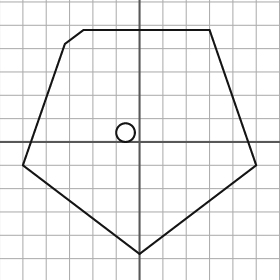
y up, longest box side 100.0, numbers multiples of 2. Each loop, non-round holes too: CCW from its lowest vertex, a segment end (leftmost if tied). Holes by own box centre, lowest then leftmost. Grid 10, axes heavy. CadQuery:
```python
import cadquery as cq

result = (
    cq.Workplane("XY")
    .moveTo(0.0, -48.0)
    .lineTo(50.0, -10.0)
    .lineTo(30.0, 48.0)
    .lineTo(-24.0, 48.0)
    .lineTo(-32.0, 42.0)
    .lineTo(-50.0, -10.0)
    .close()
    .moveTo(-6.0, 4.0)
    .circle(4.0)
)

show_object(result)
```